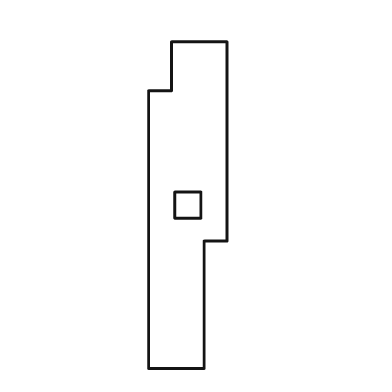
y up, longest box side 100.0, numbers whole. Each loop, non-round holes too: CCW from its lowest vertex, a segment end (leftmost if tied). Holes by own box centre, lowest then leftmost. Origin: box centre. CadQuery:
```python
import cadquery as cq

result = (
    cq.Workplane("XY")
    .moveTo(-12.0, -50.0)
    .lineTo(5.0, -50.0)
    .lineTo(5.0, -11.0)
    .lineTo(12.0, -11.0)
    .lineTo(12.0, 50.0)
    .lineTo(-5.0, 50.0)
    .lineTo(-5.0, 35.0)
    .lineTo(-12.0, 35.0)
    .close()
    .moveTo(-4.0, -4.0)
    .lineTo(4.0, -4.0)
    .lineTo(4.0, 4.0)
    .lineTo(-4.0, 4.0)
    .close()
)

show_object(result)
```